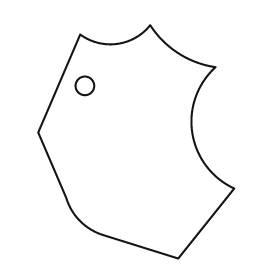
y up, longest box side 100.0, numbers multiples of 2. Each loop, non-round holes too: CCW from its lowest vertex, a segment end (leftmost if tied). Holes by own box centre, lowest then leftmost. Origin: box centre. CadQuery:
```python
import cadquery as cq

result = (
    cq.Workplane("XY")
    .moveTo(18.0, -50.0)
    .lineTo(42.0, -20.0)
    .threePointArc((24.0, 4.0), (34.0, 32.0))
    .threePointArc((18.0, 38.0), (6.0, 50.0))
    .threePointArc((-8.0, 42.0), (-24.0, 46.0))
    .lineTo(-42.0, 4.0)
    .lineTo(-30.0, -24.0)
    .threePointArc((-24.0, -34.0), (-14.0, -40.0))
    .close()
    .moveTo(-22.0, 24.0)
    .circle(4.0)
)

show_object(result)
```